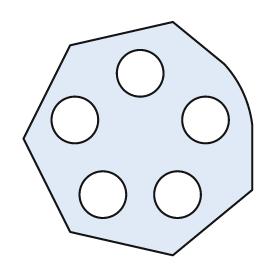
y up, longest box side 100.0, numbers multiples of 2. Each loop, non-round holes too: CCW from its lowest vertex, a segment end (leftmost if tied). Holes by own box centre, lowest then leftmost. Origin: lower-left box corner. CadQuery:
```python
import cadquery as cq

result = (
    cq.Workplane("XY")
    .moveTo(64.0, 0.0)
    .lineTo(98.0, 28.0)
    .lineTo(98.0, 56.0)
    .threePointArc((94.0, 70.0), (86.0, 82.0))
    .lineTo(64.0, 100.0)
    .lineTo(20.0, 90.0)
    .lineTo(0.0, 50.0)
    .lineTo(20.0, 10.0)
    .close()
    .moveTo(34.0, 26.0)
    .circle(10.0)
    .moveTo(66.0, 26.0)
    .circle(10.0)
    .moveTo(22.0, 58.0)
    .circle(10.0)
    .moveTo(78.0, 58.0)
    .circle(10.0)
    .moveTo(50.0, 78.0)
    .circle(10.0)
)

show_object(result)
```